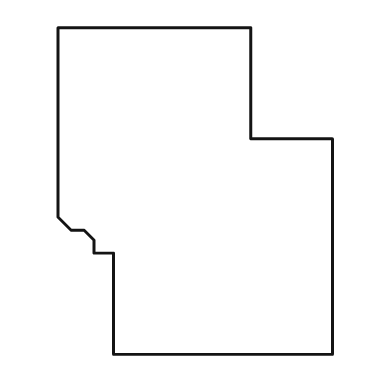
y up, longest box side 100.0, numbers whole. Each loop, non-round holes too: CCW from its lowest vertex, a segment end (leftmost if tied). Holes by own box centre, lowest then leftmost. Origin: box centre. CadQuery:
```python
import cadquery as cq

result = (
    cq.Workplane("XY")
    .moveTo(-25.0, -50.0)
    .lineTo(42.0, -50.0)
    .lineTo(42.0, 16.0)
    .lineTo(17.0, 16.0)
    .lineTo(17.0, 50.0)
    .lineTo(-42.0, 50.0)
    .lineTo(-42.0, -8.0)
    .lineTo(-38.0, -12.0)
    .lineTo(-34.0, -12.0)
    .lineTo(-31.0, -15.0)
    .lineTo(-31.0, -19.0)
    .lineTo(-25.0, -19.0)
    .close()
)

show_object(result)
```